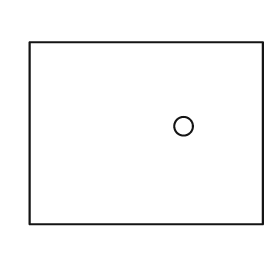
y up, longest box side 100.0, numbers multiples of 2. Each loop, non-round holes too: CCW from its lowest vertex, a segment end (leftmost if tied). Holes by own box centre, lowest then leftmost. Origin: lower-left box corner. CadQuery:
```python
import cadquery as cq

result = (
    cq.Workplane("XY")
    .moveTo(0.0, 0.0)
    .lineTo(100.0, 0.0)
    .lineTo(100.0, 78.0)
    .lineTo(0.0, 78.0)
    .close()
    .moveTo(66.0, 42.0)
    .circle(4.0)
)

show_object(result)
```